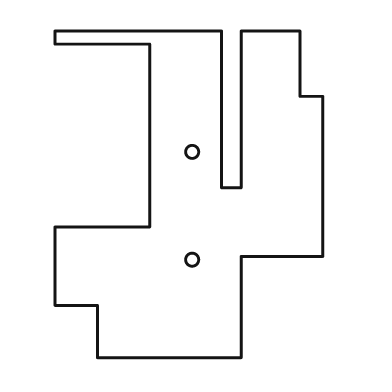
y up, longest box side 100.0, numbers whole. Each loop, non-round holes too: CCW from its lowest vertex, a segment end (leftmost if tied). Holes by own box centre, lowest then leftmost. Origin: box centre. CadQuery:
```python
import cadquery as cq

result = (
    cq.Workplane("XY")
    .moveTo(-28.0, -50.0)
    .lineTo(16.0, -50.0)
    .lineTo(16.0, -19.0)
    .lineTo(41.0, -19.0)
    .lineTo(41.0, 30.0)
    .lineTo(34.0, 30.0)
    .lineTo(34.0, 50.0)
    .lineTo(16.0, 50.0)
    .lineTo(16.0, 2.0)
    .lineTo(10.0, 2.0)
    .lineTo(10.0, 50.0)
    .lineTo(-41.0, 50.0)
    .lineTo(-41.0, 46.0)
    .lineTo(-12.0, 46.0)
    .lineTo(-12.0, -10.0)
    .lineTo(-41.0, -10.0)
    .lineTo(-41.0, -34.0)
    .lineTo(-28.0, -34.0)
    .close()
    .moveTo(1.0, -20.0)
    .circle(2.0)
    .moveTo(1.0, 13.0)
    .circle(2.0)
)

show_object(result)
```